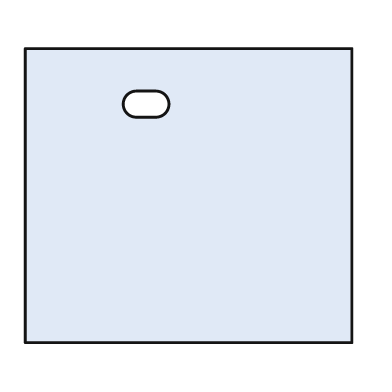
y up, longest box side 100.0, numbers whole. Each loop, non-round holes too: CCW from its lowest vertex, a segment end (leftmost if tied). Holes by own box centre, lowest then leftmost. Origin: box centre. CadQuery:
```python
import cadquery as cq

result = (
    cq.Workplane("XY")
    .moveTo(-50.0, -45.0)
    .lineTo(50.0, -45.0)
    .lineTo(50.0, 45.0)
    .lineTo(-50.0, 45.0)
    .close()
    .moveTo(-16.0, 24.0)
    .lineTo(-10.0, 24.0)
    .threePointArc((-6.0, 28.0), (-10.0, 32.0))
    .lineTo(-16.0, 32.0)
    .threePointArc((-20.0, 28.0), (-16.0, 24.0))
    .close()
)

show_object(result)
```